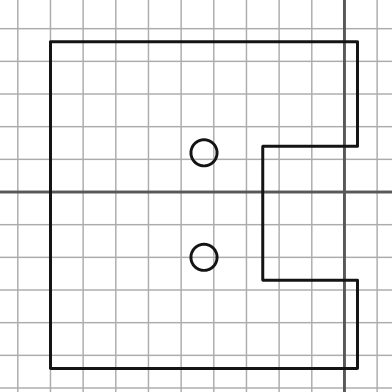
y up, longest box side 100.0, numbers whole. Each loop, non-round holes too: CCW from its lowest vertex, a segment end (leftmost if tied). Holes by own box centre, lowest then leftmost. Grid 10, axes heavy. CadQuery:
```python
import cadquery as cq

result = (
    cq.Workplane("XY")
    .moveTo(-90.0, -54.0)
    .lineTo(4.0, -54.0)
    .lineTo(4.0, -27.0)
    .lineTo(-25.0, -27.0)
    .lineTo(-25.0, 14.0)
    .lineTo(4.0, 14.0)
    .lineTo(4.0, 46.0)
    .lineTo(-90.0, 46.0)
    .close()
    .moveTo(-43.0, -20.0)
    .circle(4.0)
    .moveTo(-43.0, 12.0)
    .circle(4.0)
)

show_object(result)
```